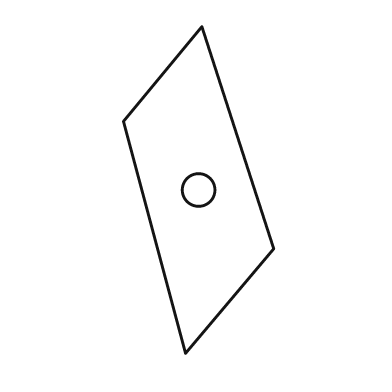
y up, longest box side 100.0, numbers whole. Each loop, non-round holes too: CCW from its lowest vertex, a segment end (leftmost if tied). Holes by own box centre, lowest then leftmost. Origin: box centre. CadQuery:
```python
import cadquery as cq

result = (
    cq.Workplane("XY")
    .moveTo(-4.0, -50.0)
    .lineTo(23.0, -18.0)
    .lineTo(1.0, 50.0)
    .lineTo(-23.0, 21.0)
    .close()
    .moveTo(0.0, 0.0)
    .circle(5.0)
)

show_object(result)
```